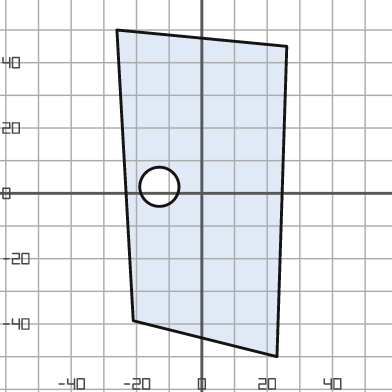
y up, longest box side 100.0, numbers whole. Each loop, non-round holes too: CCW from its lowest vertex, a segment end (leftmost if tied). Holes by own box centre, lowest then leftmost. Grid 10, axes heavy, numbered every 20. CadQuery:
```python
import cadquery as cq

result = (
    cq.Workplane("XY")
    .moveTo(23.0, -50.0)
    .lineTo(26.0, 45.0)
    .lineTo(-26.0, 50.0)
    .lineTo(-21.0, -39.0)
    .close()
    .moveTo(-13.0, 2.0)
    .circle(6.0)
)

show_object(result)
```